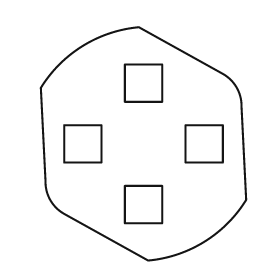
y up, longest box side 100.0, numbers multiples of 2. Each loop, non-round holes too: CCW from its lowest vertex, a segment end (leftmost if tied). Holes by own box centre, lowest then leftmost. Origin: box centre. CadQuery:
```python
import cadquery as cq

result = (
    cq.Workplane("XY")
    .moveTo(2.0, -50.0)
    .threePointArc((26.0, -42.0), (44.0, -24.0))
    .lineTo(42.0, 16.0)
    .threePointArc((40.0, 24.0), (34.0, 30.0))
    .lineTo(-2.0, 50.0)
    .threePointArc((-26.0, 42.0), (-44.0, 24.0))
    .lineTo(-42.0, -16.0)
    .threePointArc((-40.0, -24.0), (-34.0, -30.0))
    .close()
    .moveTo(-8.0, -34.0)
    .lineTo(8.0, -34.0)
    .lineTo(8.0, -18.0)
    .lineTo(-8.0, -18.0)
    .close()
    .moveTo(-34.0, -8.0)
    .lineTo(-18.0, -8.0)
    .lineTo(-18.0, 8.0)
    .lineTo(-34.0, 8.0)
    .close()
    .moveTo(18.0, -8.0)
    .lineTo(34.0, -8.0)
    .lineTo(34.0, 8.0)
    .lineTo(18.0, 8.0)
    .close()
    .moveTo(-8.0, 18.0)
    .lineTo(8.0, 18.0)
    .lineTo(8.0, 34.0)
    .lineTo(-8.0, 34.0)
    .close()
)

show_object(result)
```